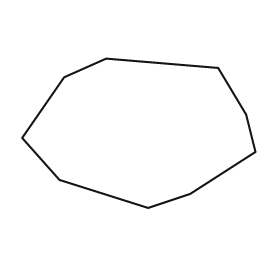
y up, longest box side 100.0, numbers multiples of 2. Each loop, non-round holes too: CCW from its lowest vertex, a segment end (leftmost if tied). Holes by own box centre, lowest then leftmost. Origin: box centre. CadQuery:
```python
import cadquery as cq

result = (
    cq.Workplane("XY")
    .moveTo(4.0, -32.0)
    .lineTo(22.0, -26.0)
    .lineTo(50.0, -8.0)
    .lineTo(46.0, 8.0)
    .lineTo(34.0, 28.0)
    .lineTo(-14.0, 32.0)
    .lineTo(-32.0, 24.0)
    .lineTo(-50.0, -2.0)
    .lineTo(-34.0, -20.0)
    .close()
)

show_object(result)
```